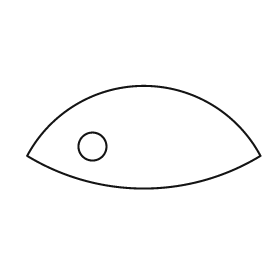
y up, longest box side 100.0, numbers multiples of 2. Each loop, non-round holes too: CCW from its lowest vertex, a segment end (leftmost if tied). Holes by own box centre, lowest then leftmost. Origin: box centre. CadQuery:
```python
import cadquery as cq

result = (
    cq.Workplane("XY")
    .moveTo(-50.0, -8.0)
    .threePointArc((0.0, -22.0), (50.0, -8.0))
    .threePointArc((0.0, 22.0), (-50.0, -8.0))
    .close()
    .moveTo(-22.0, -4.0)
    .circle(6.0)
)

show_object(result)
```